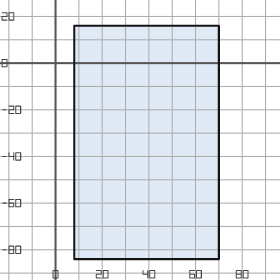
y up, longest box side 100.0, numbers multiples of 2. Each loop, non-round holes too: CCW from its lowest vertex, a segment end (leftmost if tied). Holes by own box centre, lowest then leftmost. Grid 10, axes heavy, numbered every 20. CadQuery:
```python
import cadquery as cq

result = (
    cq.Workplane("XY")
    .moveTo(8.0, -84.0)
    .lineTo(70.0, -84.0)
    .lineTo(70.0, 16.0)
    .lineTo(8.0, 16.0)
    .close()
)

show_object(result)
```